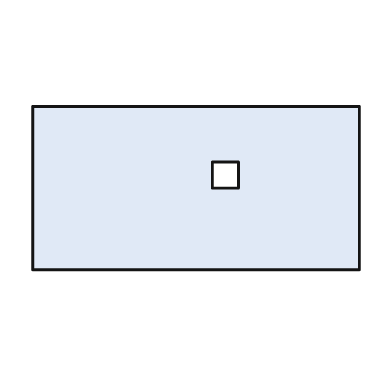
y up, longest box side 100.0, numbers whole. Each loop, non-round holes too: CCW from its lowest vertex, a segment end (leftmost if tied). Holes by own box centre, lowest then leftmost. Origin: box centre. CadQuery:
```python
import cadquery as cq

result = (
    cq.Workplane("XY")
    .moveTo(-50.0, -25.0)
    .lineTo(50.0, -25.0)
    .lineTo(50.0, 25.0)
    .lineTo(-50.0, 25.0)
    .close()
    .moveTo(5.0, 0.0)
    .lineTo(13.0, 0.0)
    .lineTo(13.0, 8.0)
    .lineTo(5.0, 8.0)
    .close()
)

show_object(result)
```